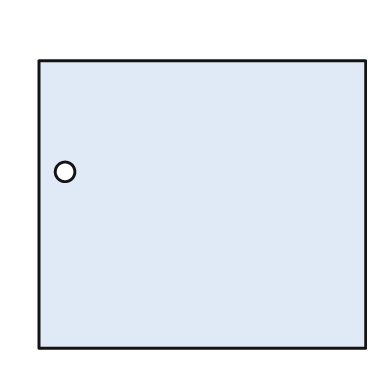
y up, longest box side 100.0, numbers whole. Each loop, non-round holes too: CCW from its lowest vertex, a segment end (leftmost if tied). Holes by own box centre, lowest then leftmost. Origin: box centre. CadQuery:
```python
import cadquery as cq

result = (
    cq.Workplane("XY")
    .moveTo(-50.0, -44.0)
    .lineTo(50.0, -44.0)
    .lineTo(50.0, 44.0)
    .lineTo(-50.0, 44.0)
    .close()
    .moveTo(-42.0, 10.0)
    .circle(3.0)
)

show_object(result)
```